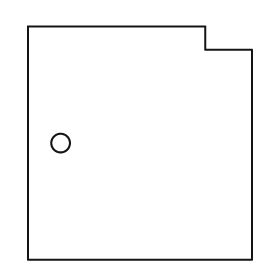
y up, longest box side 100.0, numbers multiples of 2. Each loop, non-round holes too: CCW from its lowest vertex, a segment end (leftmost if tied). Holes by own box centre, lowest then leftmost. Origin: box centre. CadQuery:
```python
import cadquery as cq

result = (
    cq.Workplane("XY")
    .moveTo(-48.0, -50.0)
    .lineTo(48.0, -50.0)
    .lineTo(48.0, 40.0)
    .lineTo(28.0, 40.0)
    .lineTo(28.0, 50.0)
    .lineTo(-48.0, 50.0)
    .close()
    .moveTo(-34.0, 0.0)
    .circle(4.0)
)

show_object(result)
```